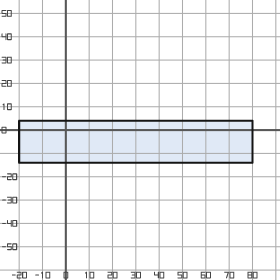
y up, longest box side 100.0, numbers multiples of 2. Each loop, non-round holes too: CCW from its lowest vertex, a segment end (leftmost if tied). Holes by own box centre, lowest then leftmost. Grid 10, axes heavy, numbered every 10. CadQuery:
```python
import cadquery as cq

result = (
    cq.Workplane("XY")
    .moveTo(-20.0, -14.0)
    .lineTo(80.0, -14.0)
    .lineTo(80.0, 4.0)
    .lineTo(-20.0, 4.0)
    .close()
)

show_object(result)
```